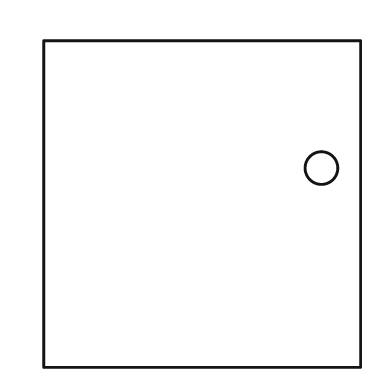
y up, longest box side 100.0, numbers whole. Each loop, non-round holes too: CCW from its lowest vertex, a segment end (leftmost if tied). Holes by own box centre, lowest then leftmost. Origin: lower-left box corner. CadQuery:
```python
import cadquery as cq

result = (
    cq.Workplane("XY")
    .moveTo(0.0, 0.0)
    .lineTo(97.0, 0.0)
    .lineTo(97.0, 100.0)
    .lineTo(0.0, 100.0)
    .close()
    .moveTo(85.0, 61.0)
    .circle(5.0)
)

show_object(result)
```